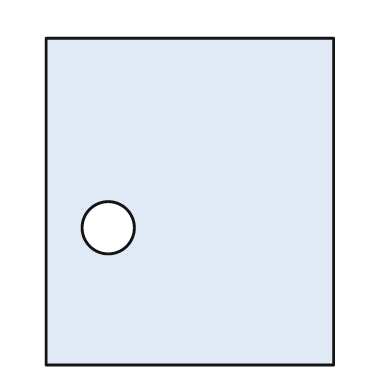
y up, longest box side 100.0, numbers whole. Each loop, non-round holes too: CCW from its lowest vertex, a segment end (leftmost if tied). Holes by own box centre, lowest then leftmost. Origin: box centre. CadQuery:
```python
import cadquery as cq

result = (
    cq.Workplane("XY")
    .moveTo(-44.0, -50.0)
    .lineTo(44.0, -50.0)
    .lineTo(44.0, 50.0)
    .lineTo(-44.0, 50.0)
    .close()
    .moveTo(-25.0, -8.0)
    .circle(8.0)
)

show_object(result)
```